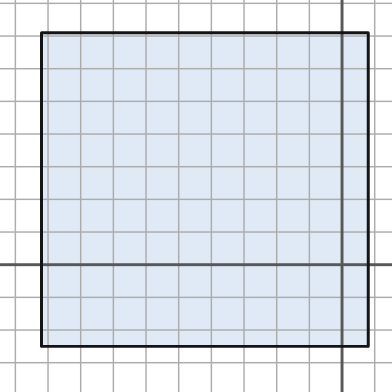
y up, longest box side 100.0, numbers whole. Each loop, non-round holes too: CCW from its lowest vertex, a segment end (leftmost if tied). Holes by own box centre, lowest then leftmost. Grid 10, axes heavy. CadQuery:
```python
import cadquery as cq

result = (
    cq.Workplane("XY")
    .moveTo(-92.0, -25.0)
    .lineTo(8.0, -25.0)
    .lineTo(8.0, 71.0)
    .lineTo(-92.0, 71.0)
    .close()
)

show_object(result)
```